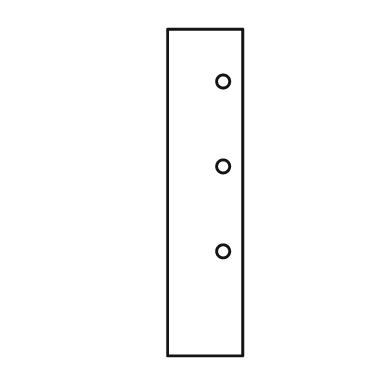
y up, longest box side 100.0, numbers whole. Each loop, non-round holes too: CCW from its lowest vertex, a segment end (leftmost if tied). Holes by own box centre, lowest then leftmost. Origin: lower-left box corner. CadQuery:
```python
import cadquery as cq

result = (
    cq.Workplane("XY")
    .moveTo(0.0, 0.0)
    .lineTo(23.0, 0.0)
    .lineTo(23.0, 100.0)
    .lineTo(0.0, 100.0)
    .close()
    .moveTo(17.0, 32.0)
    .circle(2.0)
    .moveTo(17.0, 58.0)
    .circle(2.0)
    .moveTo(17.0, 84.0)
    .circle(2.0)
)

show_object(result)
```